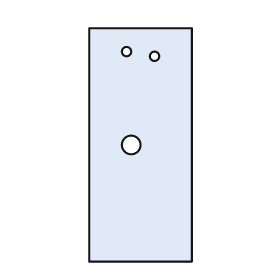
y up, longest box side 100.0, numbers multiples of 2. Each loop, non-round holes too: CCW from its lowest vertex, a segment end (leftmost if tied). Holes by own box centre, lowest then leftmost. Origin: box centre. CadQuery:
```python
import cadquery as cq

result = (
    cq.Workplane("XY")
    .moveTo(-22.0, -50.0)
    .lineTo(22.0, -50.0)
    .lineTo(22.0, 50.0)
    .lineTo(-22.0, 50.0)
    .close()
    .moveTo(-4.0, 0.0)
    .circle(4.0)
    .moveTo(6.0, 38.0)
    .circle(2.0)
    .moveTo(-6.0, 40.0)
    .circle(2.0)
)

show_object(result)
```